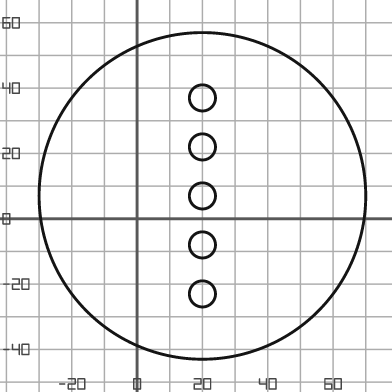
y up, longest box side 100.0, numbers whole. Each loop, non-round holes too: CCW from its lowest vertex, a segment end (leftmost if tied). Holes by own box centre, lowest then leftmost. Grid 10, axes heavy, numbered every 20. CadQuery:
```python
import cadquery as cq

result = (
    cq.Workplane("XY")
    .moveTo(20.0, 7.0)
    .circle(50.0)
    .moveTo(20.0, -23.0)
    .circle(4.0)
    .moveTo(20.0, -8.0)
    .circle(4.0)
    .moveTo(20.0, 7.0)
    .circle(4.0)
    .moveTo(20.0, 22.0)
    .circle(4.0)
    .moveTo(20.0, 37.0)
    .circle(4.0)
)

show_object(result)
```